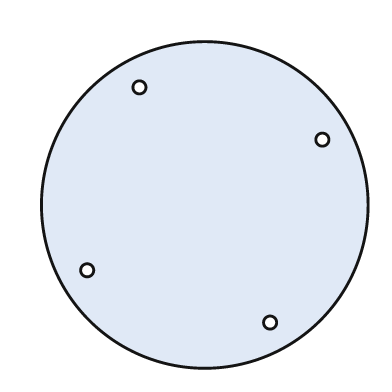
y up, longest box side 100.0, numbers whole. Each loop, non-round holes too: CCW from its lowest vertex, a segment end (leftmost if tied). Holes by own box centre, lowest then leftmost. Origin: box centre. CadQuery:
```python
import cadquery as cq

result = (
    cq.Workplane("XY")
    .moveTo(0.0, 0.0)
    .circle(50.0)
    .moveTo(20.0, -36.0)
    .circle(2.0)
    .moveTo(-36.0, -20.0)
    .circle(2.0)
    .moveTo(36.0, 20.0)
    .circle(2.0)
    .moveTo(-20.0, 36.0)
    .circle(2.0)
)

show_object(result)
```